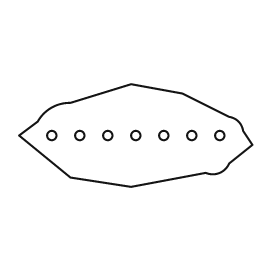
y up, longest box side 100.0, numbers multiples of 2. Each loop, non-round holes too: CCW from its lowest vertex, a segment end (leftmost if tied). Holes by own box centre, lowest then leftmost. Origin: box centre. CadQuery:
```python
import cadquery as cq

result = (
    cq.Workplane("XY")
    .moveTo(-2.0, -22.0)
    .lineTo(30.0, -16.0)
    .threePointArc((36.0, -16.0), (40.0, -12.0))
    .lineTo(50.0, -4.0)
    .lineTo(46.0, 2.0)
    .threePointArc((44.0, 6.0), (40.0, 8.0))
    .lineTo(20.0, 18.0)
    .lineTo(-2.0, 22.0)
    .lineTo(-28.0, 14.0)
    .threePointArc((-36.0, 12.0), (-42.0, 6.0))
    .lineTo(-50.0, 0.0)
    .lineTo(-28.0, -18.0)
    .close()
    .moveTo(-36.0, 0.0)
    .circle(2.0)
    .moveTo(-24.0, 0.0)
    .circle(2.0)
    .moveTo(-12.0, 0.0)
    .circle(2.0)
    .moveTo(0.0, 0.0)
    .circle(2.0)
    .moveTo(12.0, 0.0)
    .circle(2.0)
    .moveTo(24.0, 0.0)
    .circle(2.0)
    .moveTo(36.0, 0.0)
    .circle(2.0)
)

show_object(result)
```